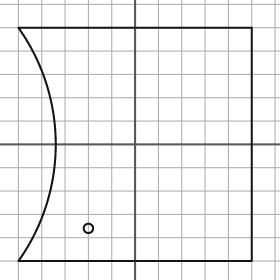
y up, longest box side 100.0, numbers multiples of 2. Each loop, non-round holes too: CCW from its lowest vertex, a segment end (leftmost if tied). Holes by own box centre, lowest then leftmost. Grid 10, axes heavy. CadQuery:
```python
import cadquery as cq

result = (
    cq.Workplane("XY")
    .moveTo(-50.0, -50.0)
    .lineTo(50.0, -50.0)
    .lineTo(50.0, 50.0)
    .lineTo(-50.0, 50.0)
    .threePointArc((-34.0, 0.0), (-50.0, -50.0))
    .close()
    .moveTo(-20.0, -36.0)
    .circle(2.0)
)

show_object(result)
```